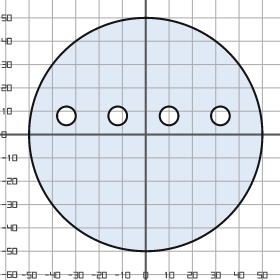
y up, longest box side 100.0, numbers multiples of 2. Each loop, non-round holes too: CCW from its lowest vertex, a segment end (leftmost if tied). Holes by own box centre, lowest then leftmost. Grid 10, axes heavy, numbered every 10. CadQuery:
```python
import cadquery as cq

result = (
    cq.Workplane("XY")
    .moveTo(0.0, 0.0)
    .circle(50.0)
    .moveTo(-34.0, 8.0)
    .circle(4.0)
    .moveTo(-12.0, 8.0)
    .circle(4.0)
    .moveTo(10.0, 8.0)
    .circle(4.0)
    .moveTo(32.0, 8.0)
    .circle(4.0)
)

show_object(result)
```